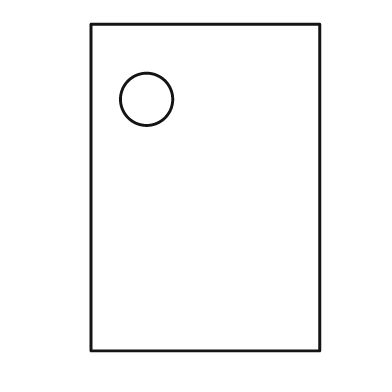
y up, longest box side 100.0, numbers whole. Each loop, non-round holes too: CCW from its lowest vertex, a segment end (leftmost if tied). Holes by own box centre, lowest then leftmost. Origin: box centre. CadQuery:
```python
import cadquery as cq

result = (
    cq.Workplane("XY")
    .moveTo(-35.0, -50.0)
    .lineTo(35.0, -50.0)
    .lineTo(35.0, 50.0)
    .lineTo(-35.0, 50.0)
    .close()
    .moveTo(-18.0, 27.0)
    .circle(8.0)
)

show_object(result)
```